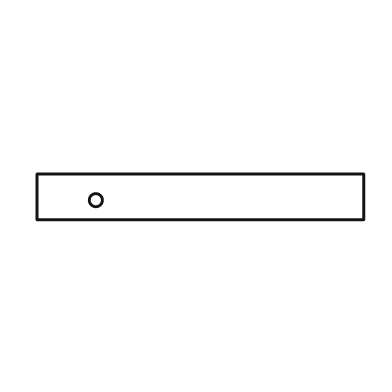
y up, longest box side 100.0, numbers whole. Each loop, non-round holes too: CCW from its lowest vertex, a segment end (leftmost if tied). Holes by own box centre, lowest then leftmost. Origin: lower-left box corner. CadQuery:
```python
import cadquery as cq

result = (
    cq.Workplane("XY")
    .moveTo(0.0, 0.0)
    .lineTo(100.0, 0.0)
    .lineTo(100.0, 14.0)
    .lineTo(0.0, 14.0)
    .close()
    .moveTo(18.0, 6.0)
    .circle(2.0)
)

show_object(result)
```